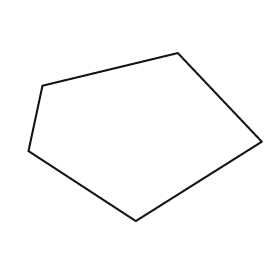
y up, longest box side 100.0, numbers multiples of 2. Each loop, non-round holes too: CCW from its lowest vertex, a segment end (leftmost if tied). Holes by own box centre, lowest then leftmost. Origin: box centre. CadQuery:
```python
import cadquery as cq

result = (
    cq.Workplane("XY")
    .moveTo(-4.0, -36.0)
    .lineTo(50.0, -2.0)
    .lineTo(14.0, 36.0)
    .lineTo(-44.0, 22.0)
    .lineTo(-50.0, -6.0)
    .close()
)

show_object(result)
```